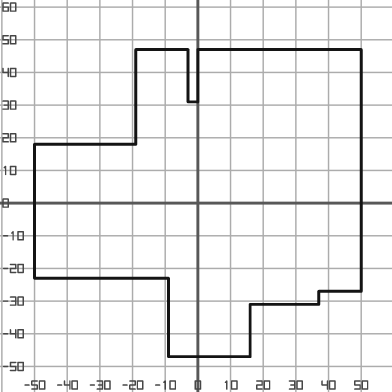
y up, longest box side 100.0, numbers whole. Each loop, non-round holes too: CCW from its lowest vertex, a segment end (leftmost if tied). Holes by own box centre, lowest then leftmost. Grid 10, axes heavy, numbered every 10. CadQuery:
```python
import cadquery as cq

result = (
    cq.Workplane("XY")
    .moveTo(-9.0, -47.0)
    .lineTo(16.0, -47.0)
    .lineTo(16.0, -31.0)
    .lineTo(37.0, -31.0)
    .lineTo(37.0, -27.0)
    .lineTo(50.0, -27.0)
    .lineTo(50.0, 47.0)
    .lineTo(0.0, 47.0)
    .lineTo(0.0, 31.0)
    .lineTo(-3.0, 31.0)
    .lineTo(-3.0, 47.0)
    .lineTo(-19.0, 47.0)
    .lineTo(-19.0, 18.0)
    .lineTo(-50.0, 18.0)
    .lineTo(-50.0, -23.0)
    .lineTo(-9.0, -23.0)
    .close()
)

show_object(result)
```